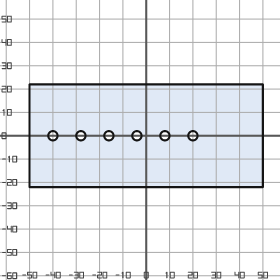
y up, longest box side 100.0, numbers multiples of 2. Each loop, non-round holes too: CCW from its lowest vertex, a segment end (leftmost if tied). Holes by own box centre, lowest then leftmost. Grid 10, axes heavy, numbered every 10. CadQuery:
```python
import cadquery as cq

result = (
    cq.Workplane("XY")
    .moveTo(-50.0, -22.0)
    .lineTo(50.0, -22.0)
    .lineTo(50.0, 22.0)
    .lineTo(-50.0, 22.0)
    .close()
    .moveTo(-40.0, 0.0)
    .circle(2.0)
    .moveTo(-28.0, 0.0)
    .circle(2.0)
    .moveTo(-16.0, 0.0)
    .circle(2.0)
    .moveTo(-4.0, 0.0)
    .circle(2.0)
    .moveTo(8.0, 0.0)
    .circle(2.0)
    .moveTo(20.0, 0.0)
    .circle(2.0)
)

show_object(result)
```